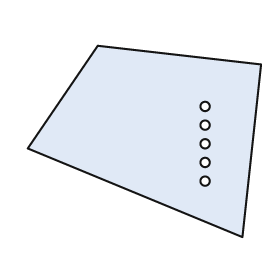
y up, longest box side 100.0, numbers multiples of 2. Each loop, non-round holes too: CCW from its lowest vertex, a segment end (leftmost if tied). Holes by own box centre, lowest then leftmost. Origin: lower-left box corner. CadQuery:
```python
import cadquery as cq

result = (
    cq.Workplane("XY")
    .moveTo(92.0, 0.0)
    .lineTo(100.0, 74.0)
    .lineTo(30.0, 82.0)
    .lineTo(0.0, 38.0)
    .close()
    .moveTo(76.0, 24.0)
    .circle(2.0)
    .moveTo(76.0, 32.0)
    .circle(2.0)
    .moveTo(76.0, 40.0)
    .circle(2.0)
    .moveTo(76.0, 48.0)
    .circle(2.0)
    .moveTo(76.0, 56.0)
    .circle(2.0)
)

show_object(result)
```